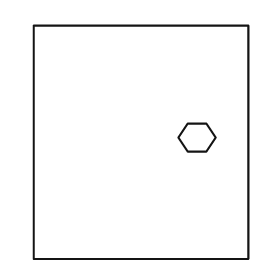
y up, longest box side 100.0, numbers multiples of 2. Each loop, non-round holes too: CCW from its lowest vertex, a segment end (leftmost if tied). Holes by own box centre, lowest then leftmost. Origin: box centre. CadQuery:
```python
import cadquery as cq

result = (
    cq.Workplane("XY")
    .moveTo(-46.0, -50.0)
    .lineTo(46.0, -50.0)
    .lineTo(46.0, 50.0)
    .lineTo(-46.0, 50.0)
    .close()
    .moveTo(20.0, -4.0)
    .lineTo(28.0, -4.0)
    .lineTo(32.0, 2.0)
    .lineTo(28.0, 8.0)
    .lineTo(20.0, 8.0)
    .lineTo(16.0, 2.0)
    .close()
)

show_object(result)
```